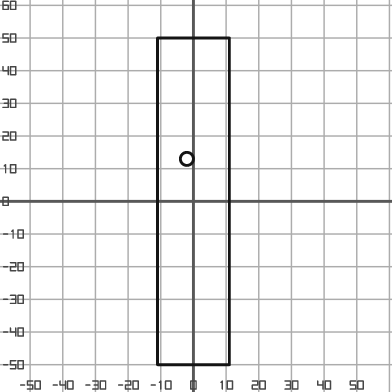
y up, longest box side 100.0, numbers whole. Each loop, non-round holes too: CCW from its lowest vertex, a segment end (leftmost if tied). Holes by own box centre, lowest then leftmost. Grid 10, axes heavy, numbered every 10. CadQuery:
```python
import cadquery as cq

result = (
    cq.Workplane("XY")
    .moveTo(-11.0, -50.0)
    .lineTo(11.0, -50.0)
    .lineTo(11.0, 50.0)
    .lineTo(-11.0, 50.0)
    .close()
    .moveTo(-2.0, 13.0)
    .circle(2.0)
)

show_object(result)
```